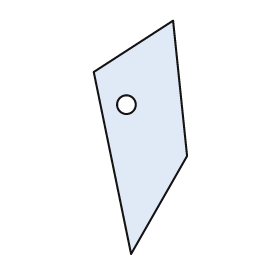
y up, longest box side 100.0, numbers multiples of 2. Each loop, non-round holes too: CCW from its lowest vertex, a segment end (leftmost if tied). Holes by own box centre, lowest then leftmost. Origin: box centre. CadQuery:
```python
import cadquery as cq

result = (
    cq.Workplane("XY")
    .moveTo(-4.0, -50.0)
    .lineTo(20.0, -8.0)
    .lineTo(14.0, 50.0)
    .lineTo(-20.0, 28.0)
    .close()
    .moveTo(-6.0, 14.0)
    .circle(4.0)
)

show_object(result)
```